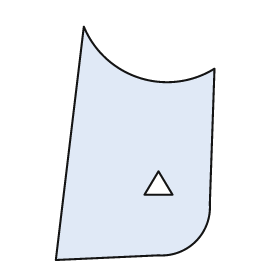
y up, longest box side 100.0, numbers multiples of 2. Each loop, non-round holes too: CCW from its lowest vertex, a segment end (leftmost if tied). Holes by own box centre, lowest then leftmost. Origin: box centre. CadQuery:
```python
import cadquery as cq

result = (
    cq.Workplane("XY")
    .moveTo(-34.0, -50.0)
    .lineTo(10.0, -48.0)
    .threePointArc((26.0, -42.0), (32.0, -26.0))
    .lineTo(34.0, 32.0)
    .threePointArc((2.0, 28.0), (-22.0, 50.0))
    .close()
    .moveTo(4.0, -22.0)
    .lineTo(16.0, -22.0)
    .lineTo(10.0, -12.0)
    .close()
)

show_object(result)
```